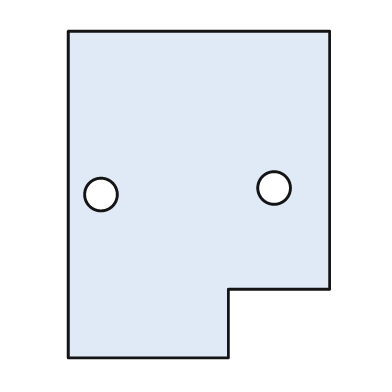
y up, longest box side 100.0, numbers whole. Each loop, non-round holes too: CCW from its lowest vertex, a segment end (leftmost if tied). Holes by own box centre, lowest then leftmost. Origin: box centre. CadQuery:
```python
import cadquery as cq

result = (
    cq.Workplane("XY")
    .moveTo(-40.0, -50.0)
    .lineTo(9.0, -50.0)
    .lineTo(9.0, -29.0)
    .lineTo(40.0, -29.0)
    .lineTo(40.0, 50.0)
    .lineTo(-40.0, 50.0)
    .close()
    .moveTo(-30.0, 0.0)
    .circle(5.0)
    .moveTo(23.0, 2.0)
    .circle(5.0)
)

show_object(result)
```